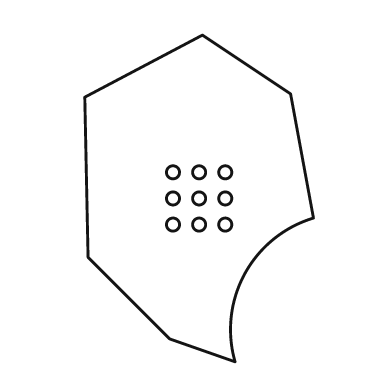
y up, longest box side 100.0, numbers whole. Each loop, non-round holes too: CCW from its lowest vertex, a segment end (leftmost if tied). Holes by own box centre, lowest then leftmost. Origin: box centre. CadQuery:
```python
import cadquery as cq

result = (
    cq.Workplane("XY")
    .moveTo(11.0, -50.0)
    .threePointArc((14.0, -23.0), (35.0, -6.0))
    .lineTo(28.0, 32.0)
    .lineTo(1.0, 50.0)
    .lineTo(-35.0, 31.0)
    .lineTo(-34.0, -18.0)
    .lineTo(-9.0, -43.0)
    .close()
    .moveTo(-8.0, -8.0)
    .circle(2.0)
    .moveTo(0.0, -8.0)
    .circle(2.0)
    .moveTo(8.0, -8.0)
    .circle(2.0)
    .moveTo(-8.0, 0.0)
    .circle(2.0)
    .moveTo(0.0, 0.0)
    .circle(2.0)
    .moveTo(8.0, 0.0)
    .circle(2.0)
    .moveTo(-8.0, 8.0)
    .circle(2.0)
    .moveTo(0.0, 8.0)
    .circle(2.0)
    .moveTo(8.0, 8.0)
    .circle(2.0)
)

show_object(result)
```